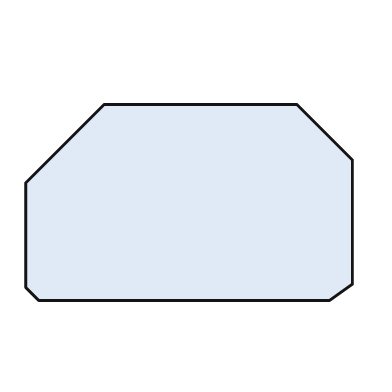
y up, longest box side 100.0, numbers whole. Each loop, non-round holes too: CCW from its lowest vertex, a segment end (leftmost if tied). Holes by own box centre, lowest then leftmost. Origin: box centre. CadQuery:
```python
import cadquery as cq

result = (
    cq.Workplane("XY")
    .moveTo(-46.0, -30.0)
    .lineTo(43.0, -30.0)
    .lineTo(50.0, -25.0)
    .lineTo(50.0, 13.0)
    .lineTo(33.0, 30.0)
    .lineTo(-26.0, 30.0)
    .lineTo(-50.0, 6.0)
    .lineTo(-50.0, -26.0)
    .close()
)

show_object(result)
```